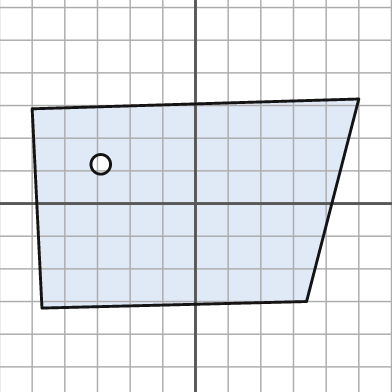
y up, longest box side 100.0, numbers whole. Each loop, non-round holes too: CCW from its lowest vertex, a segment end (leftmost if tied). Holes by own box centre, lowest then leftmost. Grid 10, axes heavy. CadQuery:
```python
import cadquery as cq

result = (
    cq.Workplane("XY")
    .moveTo(-47.0, -32.0)
    .lineTo(34.0, -30.0)
    .lineTo(50.0, 32.0)
    .lineTo(-50.0, 29.0)
    .close()
    .moveTo(-29.0, 12.0)
    .circle(3.0)
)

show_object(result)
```